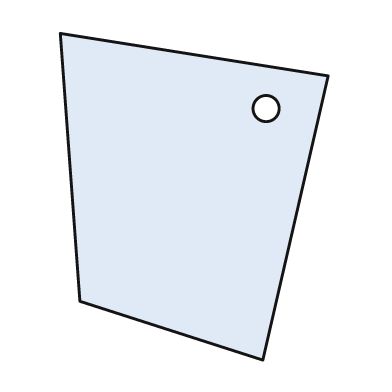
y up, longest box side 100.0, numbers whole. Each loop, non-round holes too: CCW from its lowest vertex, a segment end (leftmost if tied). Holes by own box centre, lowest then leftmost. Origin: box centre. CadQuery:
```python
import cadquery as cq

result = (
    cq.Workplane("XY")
    .moveTo(21.0, -50.0)
    .lineTo(41.0, 37.0)
    .lineTo(-41.0, 50.0)
    .lineTo(-35.0, -32.0)
    .close()
    .moveTo(22.0, 27.0)
    .circle(4.0)
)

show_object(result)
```